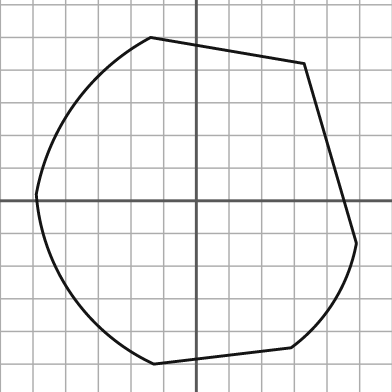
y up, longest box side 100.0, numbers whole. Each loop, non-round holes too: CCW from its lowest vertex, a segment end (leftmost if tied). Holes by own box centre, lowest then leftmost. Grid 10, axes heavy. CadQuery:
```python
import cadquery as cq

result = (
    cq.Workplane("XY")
    .moveTo(-13.0, -50.0)
    .lineTo(29.0, -45.0)
    .threePointArc((42.0, -31.0), (49.0, -13.0))
    .lineTo(33.0, 42.0)
    .lineTo(-14.0, 50.0)
    .threePointArc((-37.0, 30.0), (-49.0, 2.0))
    .threePointArc((-38.0, -29.0), (-13.0, -50.0))
    .close()
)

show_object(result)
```